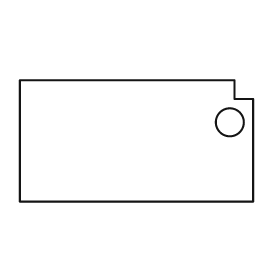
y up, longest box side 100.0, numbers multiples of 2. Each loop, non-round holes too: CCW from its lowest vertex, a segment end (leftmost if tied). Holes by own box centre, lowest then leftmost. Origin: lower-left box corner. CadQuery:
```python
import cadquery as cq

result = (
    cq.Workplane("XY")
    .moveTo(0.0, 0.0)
    .lineTo(100.0, 0.0)
    .lineTo(100.0, 44.0)
    .lineTo(92.0, 44.0)
    .lineTo(92.0, 52.0)
    .lineTo(0.0, 52.0)
    .close()
    .moveTo(90.0, 34.0)
    .circle(6.0)
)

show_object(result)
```